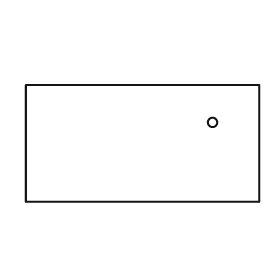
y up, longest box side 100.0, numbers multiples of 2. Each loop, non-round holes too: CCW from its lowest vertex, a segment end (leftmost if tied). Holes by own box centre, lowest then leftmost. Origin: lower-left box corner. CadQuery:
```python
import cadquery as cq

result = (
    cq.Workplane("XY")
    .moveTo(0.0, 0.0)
    .lineTo(100.0, 0.0)
    .lineTo(100.0, 50.0)
    .lineTo(0.0, 50.0)
    .close()
    .moveTo(80.0, 34.0)
    .circle(2.0)
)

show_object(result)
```